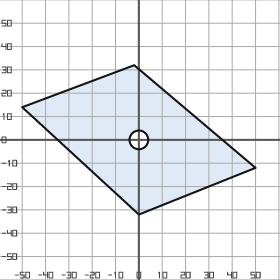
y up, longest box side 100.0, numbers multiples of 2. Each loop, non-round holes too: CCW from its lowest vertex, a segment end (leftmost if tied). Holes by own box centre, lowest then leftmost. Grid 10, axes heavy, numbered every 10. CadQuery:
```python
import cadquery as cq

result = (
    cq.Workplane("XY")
    .moveTo(0.0, -32.0)
    .lineTo(50.0, -12.0)
    .lineTo(-2.0, 32.0)
    .lineTo(-50.0, 14.0)
    .close()
    .moveTo(0.0, 0.0)
    .circle(4.0)
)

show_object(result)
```